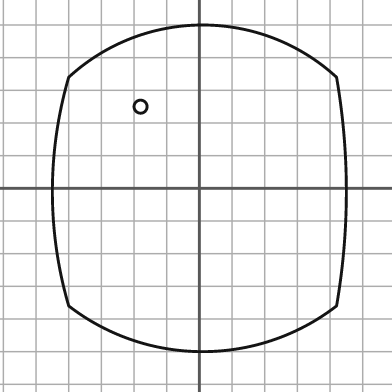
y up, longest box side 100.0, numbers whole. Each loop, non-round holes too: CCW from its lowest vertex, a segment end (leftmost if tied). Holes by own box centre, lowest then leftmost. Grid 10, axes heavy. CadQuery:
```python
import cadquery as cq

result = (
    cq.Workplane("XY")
    .moveTo(-40.0, -36.0)
    .threePointArc((1.0, -50.0), (42.0, -36.0))
    .threePointArc((45.0, -1.0), (42.0, 34.0))
    .threePointArc((1.0, 50.0), (-40.0, 34.0))
    .threePointArc((-45.0, -1.0), (-40.0, -36.0))
    .close()
    .moveTo(-18.0, 25.0)
    .circle(2.0)
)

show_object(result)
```